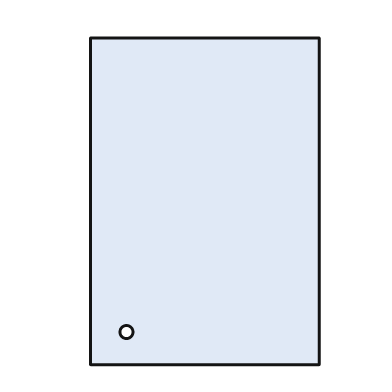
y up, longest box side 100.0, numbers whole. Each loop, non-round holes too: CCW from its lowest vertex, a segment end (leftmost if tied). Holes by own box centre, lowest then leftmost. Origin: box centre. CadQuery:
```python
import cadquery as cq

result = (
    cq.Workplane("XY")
    .moveTo(-35.0, -50.0)
    .lineTo(35.0, -50.0)
    .lineTo(35.0, 50.0)
    .lineTo(-35.0, 50.0)
    .close()
    .moveTo(-24.0, -40.0)
    .circle(2.0)
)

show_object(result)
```